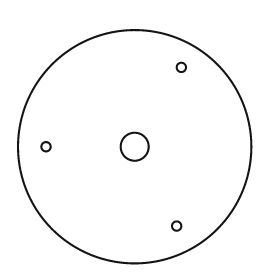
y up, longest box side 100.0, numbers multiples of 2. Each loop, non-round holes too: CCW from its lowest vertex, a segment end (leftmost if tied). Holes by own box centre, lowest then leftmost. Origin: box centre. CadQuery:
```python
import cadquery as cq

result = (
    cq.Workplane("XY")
    .moveTo(0.0, 0.0)
    .circle(50.0)
    .moveTo(18.0, -34.0)
    .circle(2.0)
    .moveTo(-38.0, 0.0)
    .circle(2.0)
    .moveTo(0.0, 0.0)
    .circle(6.0)
    .moveTo(20.0, 34.0)
    .circle(2.0)
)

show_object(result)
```